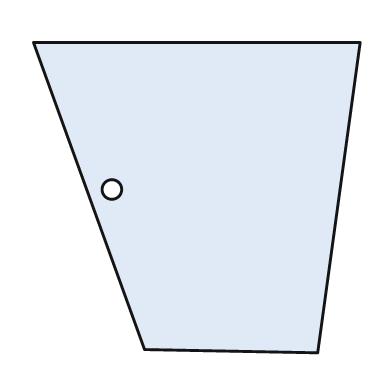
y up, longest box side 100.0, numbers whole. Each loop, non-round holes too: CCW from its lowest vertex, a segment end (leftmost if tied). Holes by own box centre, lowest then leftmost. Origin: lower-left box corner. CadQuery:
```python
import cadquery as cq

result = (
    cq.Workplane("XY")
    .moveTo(87.0, 0.0)
    .lineTo(100.0, 95.0)
    .lineTo(0.0, 95.0)
    .lineTo(34.0, 1.0)
    .close()
    .moveTo(24.0, 50.0)
    .circle(3.0)
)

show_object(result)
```